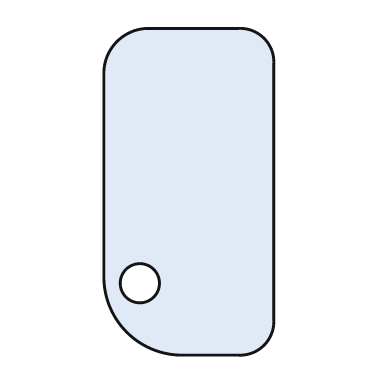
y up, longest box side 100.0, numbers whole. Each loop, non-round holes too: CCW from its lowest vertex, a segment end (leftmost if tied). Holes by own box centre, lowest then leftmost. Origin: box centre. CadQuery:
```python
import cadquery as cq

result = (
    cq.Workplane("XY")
    .moveTo(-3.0, -50.0)
    .lineTo(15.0, -50.0)
    .threePointArc((23.0, -47.0), (26.0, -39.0))
    .lineTo(26.0, 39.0)
    .threePointArc((23.0, 47.0), (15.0, 50.0))
    .lineTo(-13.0, 50.0)
    .threePointArc((-22.0, 46.0), (-26.0, 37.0))
    .lineTo(-26.0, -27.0)
    .threePointArc((-19.0, -43.0), (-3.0, -50.0))
    .close()
    .moveTo(-15.0, -28.0)
    .circle(6.0)
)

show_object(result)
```